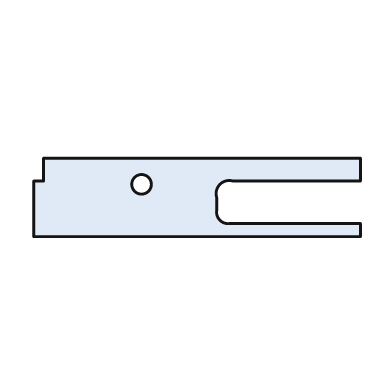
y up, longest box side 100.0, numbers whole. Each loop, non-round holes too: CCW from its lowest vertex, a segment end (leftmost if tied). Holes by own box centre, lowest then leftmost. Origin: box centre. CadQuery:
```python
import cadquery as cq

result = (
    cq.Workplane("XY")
    .moveTo(-50.0, -12.0)
    .lineTo(50.0, -12.0)
    .lineTo(50.0, -8.0)
    .lineTo(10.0, -8.0)
    .threePointArc((7.0, -7.0), (6.0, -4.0))
    .lineTo(6.0, 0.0)
    .threePointArc((7.0, 4.0), (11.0, 5.0))
    .lineTo(50.0, 5.0)
    .lineTo(50.0, 12.0)
    .lineTo(-47.0, 12.0)
    .lineTo(-47.0, 5.0)
    .lineTo(-50.0, 5.0)
    .close()
    .moveTo(-17.0, 4.0)
    .circle(3.0)
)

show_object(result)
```